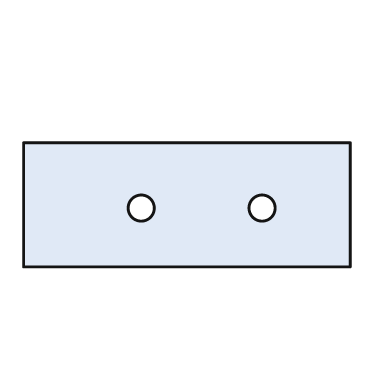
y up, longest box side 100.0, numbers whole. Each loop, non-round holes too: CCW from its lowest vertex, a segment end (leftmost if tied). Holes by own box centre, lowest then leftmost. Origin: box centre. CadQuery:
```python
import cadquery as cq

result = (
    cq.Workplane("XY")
    .moveTo(-50.0, -19.0)
    .lineTo(50.0, -19.0)
    .lineTo(50.0, 19.0)
    .lineTo(-50.0, 19.0)
    .close()
    .moveTo(-14.0, -1.0)
    .circle(4.0)
    .moveTo(23.0, -1.0)
    .circle(4.0)
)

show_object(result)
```